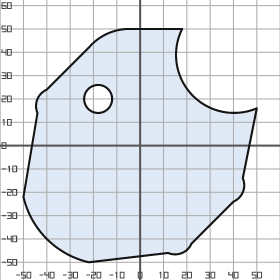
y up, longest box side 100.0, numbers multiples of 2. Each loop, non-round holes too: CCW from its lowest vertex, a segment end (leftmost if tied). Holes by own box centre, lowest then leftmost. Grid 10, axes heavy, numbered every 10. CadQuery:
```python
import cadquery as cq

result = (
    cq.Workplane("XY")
    .moveTo(-22.0, -50.0)
    .lineTo(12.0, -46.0)
    .threePointArc((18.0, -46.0), (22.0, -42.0))
    .lineTo(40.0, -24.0)
    .threePointArc((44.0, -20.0), (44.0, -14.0))
    .lineTo(50.0, 16.0)
    .threePointArc((22.0, 22.0), (18.0, 50.0))
    .lineTo(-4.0, 50.0)
    .threePointArc((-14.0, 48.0), (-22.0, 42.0))
    .lineTo(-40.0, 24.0)
    .threePointArc((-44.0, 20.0), (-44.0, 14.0))
    .lineTo(-50.0, -22.0)
    .threePointArc((-40.0, -40.0), (-22.0, -50.0))
    .close()
    .moveTo(-18.0, 20.0)
    .circle(6.0)
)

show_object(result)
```